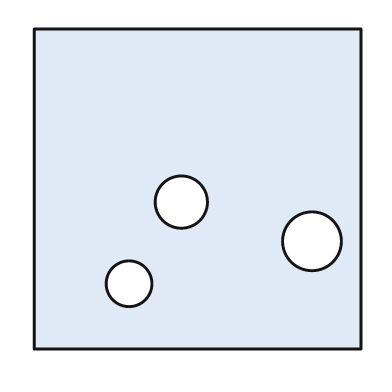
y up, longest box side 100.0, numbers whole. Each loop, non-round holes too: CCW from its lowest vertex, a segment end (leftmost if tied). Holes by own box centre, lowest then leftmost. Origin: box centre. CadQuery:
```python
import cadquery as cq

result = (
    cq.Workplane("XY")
    .moveTo(-50.0, -49.0)
    .lineTo(50.0, -49.0)
    .lineTo(50.0, 49.0)
    .lineTo(-50.0, 49.0)
    .close()
    .moveTo(-21.0, -29.0)
    .circle(7.0)
    .moveTo(35.0, -16.0)
    .circle(9.0)
    .moveTo(-5.0, -4.0)
    .circle(8.0)
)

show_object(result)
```